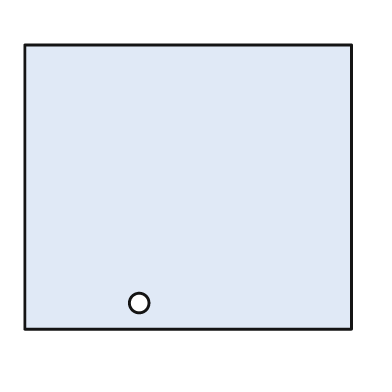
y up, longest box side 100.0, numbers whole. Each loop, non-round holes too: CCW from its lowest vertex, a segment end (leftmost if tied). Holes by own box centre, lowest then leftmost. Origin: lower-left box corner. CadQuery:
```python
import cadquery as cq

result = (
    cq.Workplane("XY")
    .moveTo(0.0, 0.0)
    .lineTo(100.0, 0.0)
    .lineTo(100.0, 87.0)
    .lineTo(0.0, 87.0)
    .close()
    .moveTo(35.0, 8.0)
    .circle(3.0)
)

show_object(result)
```